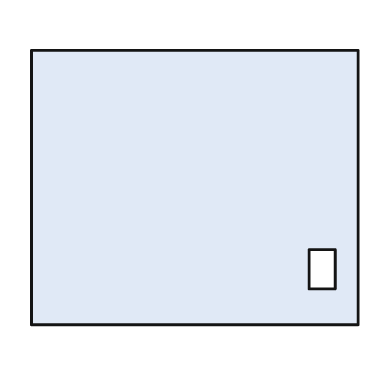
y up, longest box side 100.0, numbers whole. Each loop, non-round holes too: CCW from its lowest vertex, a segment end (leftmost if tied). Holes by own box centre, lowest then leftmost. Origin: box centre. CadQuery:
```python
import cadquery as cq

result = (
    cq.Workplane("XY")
    .moveTo(-50.0, -42.0)
    .lineTo(50.0, -42.0)
    .lineTo(50.0, 42.0)
    .lineTo(-50.0, 42.0)
    .close()
    .moveTo(35.0, -31.0)
    .lineTo(43.0, -31.0)
    .lineTo(43.0, -19.0)
    .lineTo(35.0, -19.0)
    .close()
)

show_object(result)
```